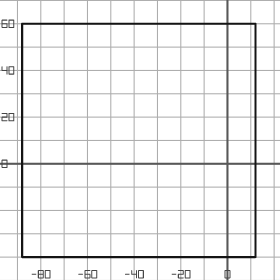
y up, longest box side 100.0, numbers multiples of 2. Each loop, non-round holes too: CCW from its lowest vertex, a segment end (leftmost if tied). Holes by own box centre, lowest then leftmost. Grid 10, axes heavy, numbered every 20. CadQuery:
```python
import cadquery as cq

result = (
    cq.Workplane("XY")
    .moveTo(-88.0, -40.0)
    .lineTo(12.0, -40.0)
    .lineTo(12.0, 60.0)
    .lineTo(-88.0, 60.0)
    .close()
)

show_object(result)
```